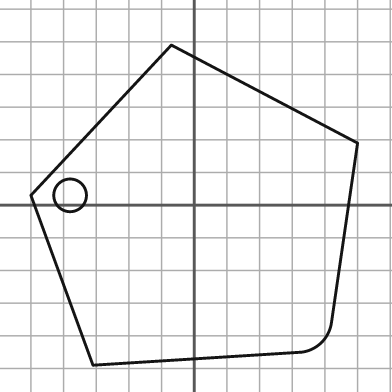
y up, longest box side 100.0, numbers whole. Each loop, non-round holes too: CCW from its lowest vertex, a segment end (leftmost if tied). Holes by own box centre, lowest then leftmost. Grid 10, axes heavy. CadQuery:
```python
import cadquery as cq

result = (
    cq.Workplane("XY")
    .moveTo(-31.0, -49.0)
    .lineTo(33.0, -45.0)
    .threePointArc((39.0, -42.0), (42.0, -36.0))
    .lineTo(50.0, 19.0)
    .lineTo(-7.0, 49.0)
    .lineTo(-50.0, 3.0)
    .close()
    .moveTo(-38.0, 3.0)
    .circle(5.0)
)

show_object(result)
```